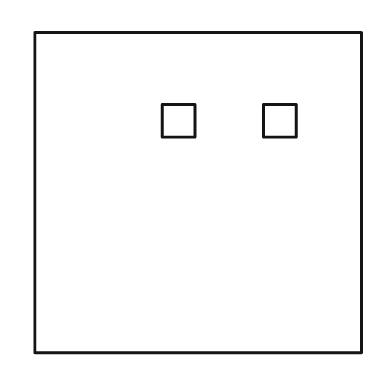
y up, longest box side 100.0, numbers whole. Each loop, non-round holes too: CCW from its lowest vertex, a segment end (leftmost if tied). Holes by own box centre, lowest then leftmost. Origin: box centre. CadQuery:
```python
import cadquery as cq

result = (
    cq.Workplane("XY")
    .moveTo(-50.0, -49.0)
    .lineTo(50.0, -49.0)
    .lineTo(50.0, 49.0)
    .lineTo(-50.0, 49.0)
    .close()
    .moveTo(-11.0, 17.0)
    .lineTo(-1.0, 17.0)
    .lineTo(-1.0, 27.0)
    .lineTo(-11.0, 27.0)
    .close()
    .moveTo(20.0, 17.0)
    .lineTo(30.0, 17.0)
    .lineTo(30.0, 27.0)
    .lineTo(20.0, 27.0)
    .close()
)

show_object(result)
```